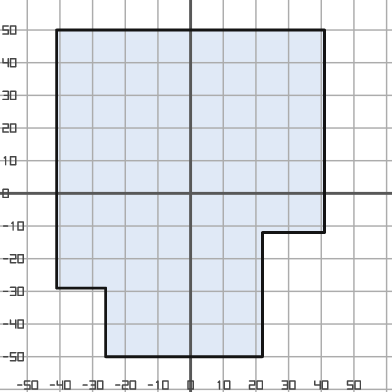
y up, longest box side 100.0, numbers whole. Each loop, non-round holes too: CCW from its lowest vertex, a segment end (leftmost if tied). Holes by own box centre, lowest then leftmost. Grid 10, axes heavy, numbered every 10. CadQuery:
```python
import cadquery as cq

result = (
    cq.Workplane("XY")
    .moveTo(-26.0, -50.0)
    .lineTo(22.0, -50.0)
    .lineTo(22.0, -12.0)
    .lineTo(41.0, -12.0)
    .lineTo(41.0, 50.0)
    .lineTo(-41.0, 50.0)
    .lineTo(-41.0, -29.0)
    .lineTo(-26.0, -29.0)
    .close()
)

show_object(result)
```